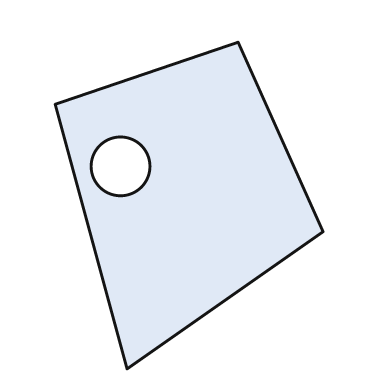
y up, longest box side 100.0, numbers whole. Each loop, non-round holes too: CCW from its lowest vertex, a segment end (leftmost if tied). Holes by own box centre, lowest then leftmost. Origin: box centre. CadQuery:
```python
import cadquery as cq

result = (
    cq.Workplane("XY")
    .moveTo(-19.0, -50.0)
    .lineTo(41.0, -8.0)
    .lineTo(15.0, 50.0)
    .lineTo(-41.0, 31.0)
    .close()
    .moveTo(-21.0, 12.0)
    .circle(9.0)
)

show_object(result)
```